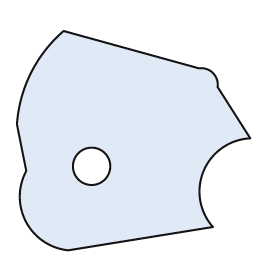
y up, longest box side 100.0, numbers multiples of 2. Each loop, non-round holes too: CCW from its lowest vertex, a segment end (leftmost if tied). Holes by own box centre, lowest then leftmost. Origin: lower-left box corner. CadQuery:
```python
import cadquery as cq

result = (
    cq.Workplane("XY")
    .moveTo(22.0, 0.0)
    .lineTo(84.0, 10.0)
    .threePointArc((80.0, 34.0), (100.0, 48.0))
    .lineTo(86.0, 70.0)
    .threePointArc((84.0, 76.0), (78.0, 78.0))
    .lineTo(20.0, 94.0)
    .threePointArc((6.0, 76.0), (0.0, 54.0))
    .lineTo(4.0, 34.0)
    .threePointArc((4.0, 12.0), (22.0, 0.0))
    .close()
    .moveTo(32.0, 36.0)
    .circle(8.0)
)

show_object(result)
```